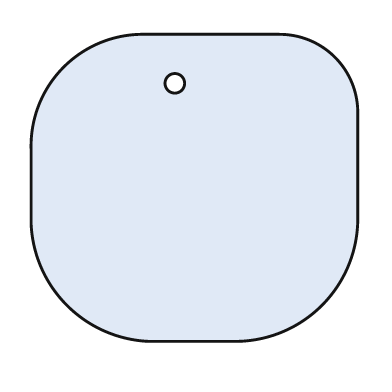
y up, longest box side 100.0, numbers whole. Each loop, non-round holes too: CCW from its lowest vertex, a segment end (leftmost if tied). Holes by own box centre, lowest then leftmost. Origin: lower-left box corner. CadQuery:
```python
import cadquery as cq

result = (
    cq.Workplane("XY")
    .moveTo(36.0, 0.0)
    .lineTo(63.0, 0.0)
    .threePointArc((89.0, 11.0), (100.0, 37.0))
    .lineTo(100.0, 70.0)
    .threePointArc((93.0, 87.0), (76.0, 94.0))
    .lineTo(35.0, 94.0)
    .threePointArc((10.0, 84.0), (0.0, 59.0))
    .lineTo(0.0, 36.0)
    .threePointArc((11.0, 11.0), (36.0, 0.0))
    .close()
    .moveTo(44.0, 79.0)
    .circle(3.0)
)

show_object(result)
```